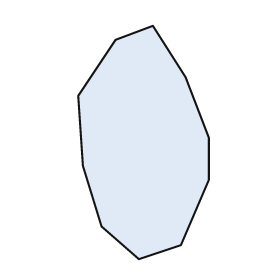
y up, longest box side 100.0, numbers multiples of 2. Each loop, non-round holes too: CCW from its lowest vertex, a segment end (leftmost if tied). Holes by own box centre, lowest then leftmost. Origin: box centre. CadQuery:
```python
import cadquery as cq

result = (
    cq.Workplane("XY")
    .moveTo(-2.0, -50.0)
    .lineTo(16.0, -44.0)
    .lineTo(28.0, -16.0)
    .lineTo(28.0, 2.0)
    .lineTo(18.0, 28.0)
    .lineTo(4.0, 50.0)
    .lineTo(-12.0, 44.0)
    .lineTo(-28.0, 20.0)
    .lineTo(-26.0, -10.0)
    .lineTo(-18.0, -36.0)
    .close()
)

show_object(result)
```